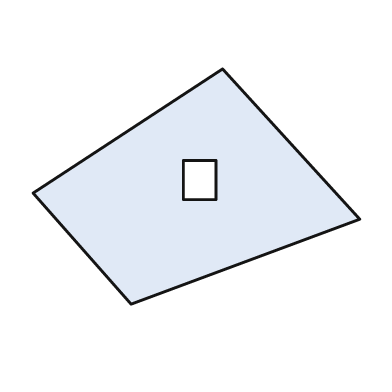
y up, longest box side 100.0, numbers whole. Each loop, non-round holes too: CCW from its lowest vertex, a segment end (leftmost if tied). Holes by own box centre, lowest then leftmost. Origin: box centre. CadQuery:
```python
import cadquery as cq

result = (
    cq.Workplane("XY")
    .moveTo(-20.0, -36.0)
    .lineTo(50.0, -10.0)
    .lineTo(8.0, 36.0)
    .lineTo(-50.0, -2.0)
    .close()
    .moveTo(-4.0, -4.0)
    .lineTo(6.0, -4.0)
    .lineTo(6.0, 8.0)
    .lineTo(-4.0, 8.0)
    .close()
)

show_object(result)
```